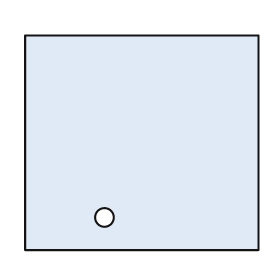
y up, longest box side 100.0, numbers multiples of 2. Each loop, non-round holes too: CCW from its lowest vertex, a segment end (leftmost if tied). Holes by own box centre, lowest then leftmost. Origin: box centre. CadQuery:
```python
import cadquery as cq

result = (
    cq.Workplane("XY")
    .moveTo(-50.0, -46.0)
    .lineTo(50.0, -46.0)
    .lineTo(50.0, 46.0)
    .lineTo(-50.0, 46.0)
    .close()
    .moveTo(-16.0, -32.0)
    .circle(4.0)
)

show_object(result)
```